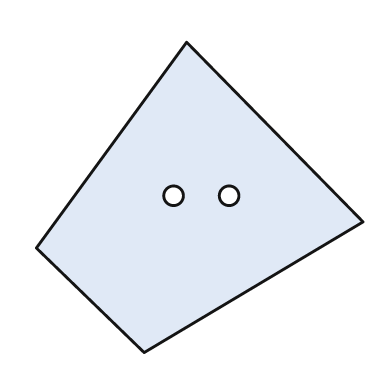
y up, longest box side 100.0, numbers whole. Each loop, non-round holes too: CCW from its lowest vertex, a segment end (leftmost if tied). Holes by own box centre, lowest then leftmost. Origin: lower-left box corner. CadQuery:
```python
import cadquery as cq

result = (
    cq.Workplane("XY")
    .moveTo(33.0, 0.0)
    .lineTo(100.0, 40.0)
    .lineTo(46.0, 95.0)
    .lineTo(0.0, 32.0)
    .close()
    .moveTo(42.0, 48.0)
    .circle(3.0)
    .moveTo(59.0, 48.0)
    .circle(3.0)
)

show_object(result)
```